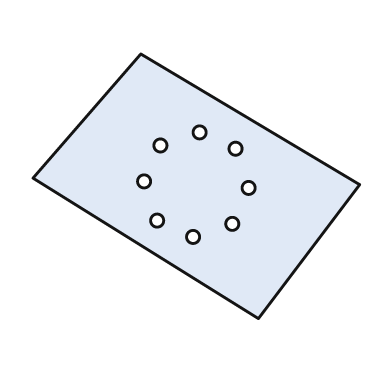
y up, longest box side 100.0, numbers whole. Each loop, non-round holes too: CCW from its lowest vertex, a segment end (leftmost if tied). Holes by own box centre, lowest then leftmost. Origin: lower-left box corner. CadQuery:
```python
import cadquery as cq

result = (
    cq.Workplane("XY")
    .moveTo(69.0, 0.0)
    .lineTo(100.0, 41.0)
    .lineTo(33.0, 81.0)
    .lineTo(0.0, 43.0)
    .close()
    .moveTo(49.0, 25.0)
    .circle(2.0)
    .moveTo(61.0, 29.0)
    .circle(2.0)
    .moveTo(38.0, 30.0)
    .circle(2.0)
    .moveTo(66.0, 40.0)
    .circle(2.0)
    .moveTo(34.0, 42.0)
    .circle(2.0)
    .moveTo(62.0, 52.0)
    .circle(2.0)
    .moveTo(39.0, 53.0)
    .circle(2.0)
    .moveTo(51.0, 57.0)
    .circle(2.0)
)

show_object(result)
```